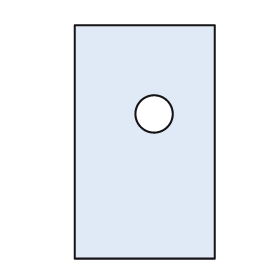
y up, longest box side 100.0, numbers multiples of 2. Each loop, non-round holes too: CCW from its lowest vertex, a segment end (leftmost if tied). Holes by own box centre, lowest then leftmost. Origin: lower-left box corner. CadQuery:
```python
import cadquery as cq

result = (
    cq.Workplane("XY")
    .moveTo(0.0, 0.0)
    .lineTo(60.0, 0.0)
    .lineTo(60.0, 100.0)
    .lineTo(0.0, 100.0)
    .close()
    .moveTo(34.0, 62.0)
    .circle(8.0)
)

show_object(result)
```